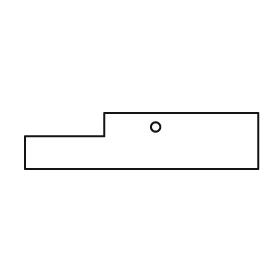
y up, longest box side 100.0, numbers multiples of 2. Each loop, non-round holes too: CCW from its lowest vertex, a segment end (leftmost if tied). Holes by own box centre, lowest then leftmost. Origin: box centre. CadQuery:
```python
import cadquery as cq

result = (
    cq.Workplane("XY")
    .moveTo(-50.0, -12.0)
    .lineTo(50.0, -12.0)
    .lineTo(50.0, 12.0)
    .lineTo(-16.0, 12.0)
    .lineTo(-16.0, 2.0)
    .lineTo(-50.0, 2.0)
    .close()
    .moveTo(6.0, 6.0)
    .circle(2.0)
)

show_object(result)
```